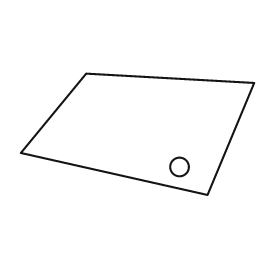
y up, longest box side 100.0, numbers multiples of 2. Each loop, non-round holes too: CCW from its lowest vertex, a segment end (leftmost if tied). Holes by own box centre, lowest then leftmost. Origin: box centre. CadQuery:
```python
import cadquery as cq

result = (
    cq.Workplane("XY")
    .moveTo(30.0, -26.0)
    .lineTo(50.0, 22.0)
    .lineTo(-22.0, 26.0)
    .lineTo(-50.0, -8.0)
    .close()
    .moveTo(18.0, -14.0)
    .circle(4.0)
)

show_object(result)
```